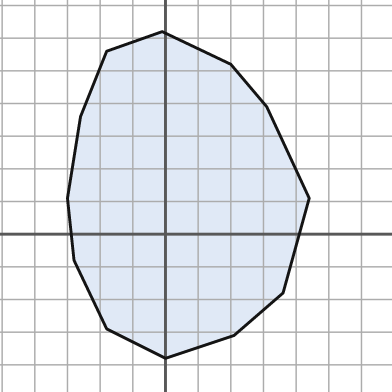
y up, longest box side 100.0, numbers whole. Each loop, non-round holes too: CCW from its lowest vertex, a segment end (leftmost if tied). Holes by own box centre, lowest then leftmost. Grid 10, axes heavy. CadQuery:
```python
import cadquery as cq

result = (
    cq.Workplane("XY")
    .moveTo(0.0, -38.0)
    .lineTo(21.0, -31.0)
    .lineTo(36.0, -18.0)
    .lineTo(44.0, 11.0)
    .lineTo(31.0, 39.0)
    .lineTo(20.0, 52.0)
    .lineTo(-1.0, 62.0)
    .lineTo(-18.0, 56.0)
    .lineTo(-26.0, 36.0)
    .lineTo(-30.0, 11.0)
    .lineTo(-28.0, -8.0)
    .lineTo(-18.0, -29.0)
    .close()
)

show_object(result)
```